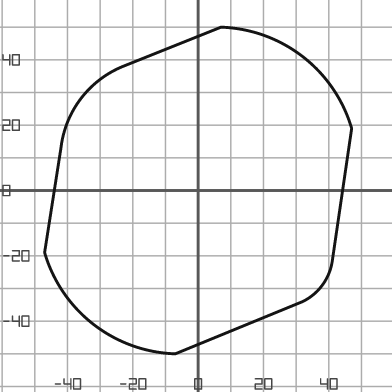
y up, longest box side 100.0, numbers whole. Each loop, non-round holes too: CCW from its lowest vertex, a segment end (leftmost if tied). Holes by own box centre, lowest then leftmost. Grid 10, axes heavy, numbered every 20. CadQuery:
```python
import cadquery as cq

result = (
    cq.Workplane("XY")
    .moveTo(-7.0, -50.0)
    .lineTo(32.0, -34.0)
    .threePointArc((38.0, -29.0), (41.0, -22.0))
    .lineTo(47.0, 19.0)
    .threePointArc((32.0, 41.0), (7.0, 50.0))
    .lineTo(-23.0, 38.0)
    .threePointArc((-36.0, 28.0), (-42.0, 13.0))
    .lineTo(-47.0, -19.0)
    .threePointArc((-32.0, -41.0), (-7.0, -50.0))
    .close()
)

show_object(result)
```